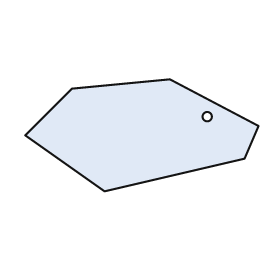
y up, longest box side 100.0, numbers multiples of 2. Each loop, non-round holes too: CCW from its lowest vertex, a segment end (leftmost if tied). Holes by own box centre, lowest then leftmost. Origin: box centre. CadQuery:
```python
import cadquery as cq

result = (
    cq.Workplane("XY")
    .moveTo(-16.0, -24.0)
    .lineTo(44.0, -10.0)
    .lineTo(50.0, 4.0)
    .lineTo(12.0, 24.0)
    .lineTo(-30.0, 20.0)
    .lineTo(-50.0, 0.0)
    .close()
    .moveTo(28.0, 8.0)
    .circle(2.0)
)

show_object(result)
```